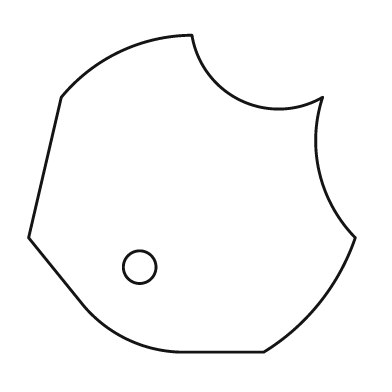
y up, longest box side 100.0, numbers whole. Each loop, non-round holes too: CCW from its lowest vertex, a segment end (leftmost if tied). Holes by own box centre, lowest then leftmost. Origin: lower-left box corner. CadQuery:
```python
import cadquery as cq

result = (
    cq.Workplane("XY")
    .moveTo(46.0, 0.0)
    .lineTo(72.0, 0.0)
    .threePointArc((89.0, 15.0), (100.0, 35.0))
    .threePointArc((89.0, 55.0), (90.0, 78.0))
    .threePointArc((65.0, 77.0), (50.0, 97.0))
    .threePointArc((28.0, 92.0), (10.0, 78.0))
    .lineTo(0.0, 35.0)
    .lineTo(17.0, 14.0)
    .threePointArc((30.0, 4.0), (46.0, 0.0))
    .close()
    .moveTo(34.0, 26.0)
    .circle(5.0)
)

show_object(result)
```